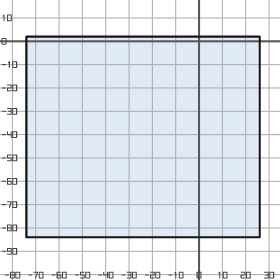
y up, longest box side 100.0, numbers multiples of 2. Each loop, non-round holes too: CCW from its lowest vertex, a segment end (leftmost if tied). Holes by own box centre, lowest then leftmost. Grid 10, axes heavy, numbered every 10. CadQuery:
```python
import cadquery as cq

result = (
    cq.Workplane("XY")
    .moveTo(-74.0, -84.0)
    .lineTo(26.0, -84.0)
    .lineTo(26.0, 2.0)
    .lineTo(-74.0, 2.0)
    .close()
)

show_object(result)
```